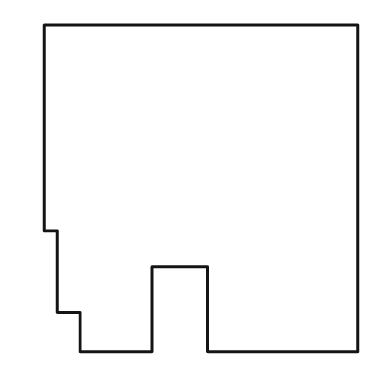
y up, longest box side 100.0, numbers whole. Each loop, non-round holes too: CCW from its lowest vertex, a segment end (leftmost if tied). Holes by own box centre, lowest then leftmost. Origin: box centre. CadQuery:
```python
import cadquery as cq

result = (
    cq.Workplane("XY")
    .moveTo(-37.0, -50.0)
    .lineTo(-15.0, -50.0)
    .lineTo(-15.0, -24.0)
    .lineTo(2.0, -24.0)
    .lineTo(2.0, -50.0)
    .lineTo(48.0, -50.0)
    .lineTo(48.0, 50.0)
    .lineTo(-48.0, 50.0)
    .lineTo(-48.0, -13.0)
    .lineTo(-44.0, -13.0)
    .lineTo(-44.0, -38.0)
    .lineTo(-37.0, -38.0)
    .close()
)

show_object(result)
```